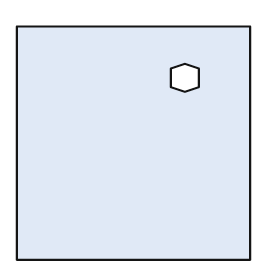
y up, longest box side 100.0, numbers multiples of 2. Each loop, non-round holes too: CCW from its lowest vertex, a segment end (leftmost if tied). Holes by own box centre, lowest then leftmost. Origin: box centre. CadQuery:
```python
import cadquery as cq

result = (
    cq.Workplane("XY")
    .moveTo(-50.0, -50.0)
    .lineTo(50.0, -50.0)
    .lineTo(50.0, 50.0)
    .lineTo(-50.0, 50.0)
    .close()
    .moveTo(22.0, 22.0)
    .lineTo(28.0, 24.0)
    .lineTo(28.0, 32.0)
    .lineTo(22.0, 34.0)
    .lineTo(16.0, 32.0)
    .lineTo(16.0, 24.0)
    .close()
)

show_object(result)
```